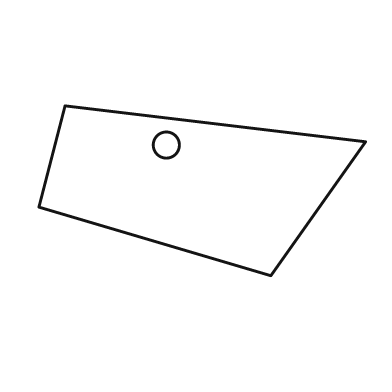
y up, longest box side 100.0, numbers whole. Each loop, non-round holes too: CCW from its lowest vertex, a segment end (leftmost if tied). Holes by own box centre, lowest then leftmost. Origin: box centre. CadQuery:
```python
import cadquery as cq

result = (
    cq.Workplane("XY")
    .moveTo(21.0, -26.0)
    .lineTo(50.0, 15.0)
    .lineTo(-42.0, 26.0)
    .lineTo(-50.0, -5.0)
    .close()
    .moveTo(-11.0, 14.0)
    .circle(4.0)
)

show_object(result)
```